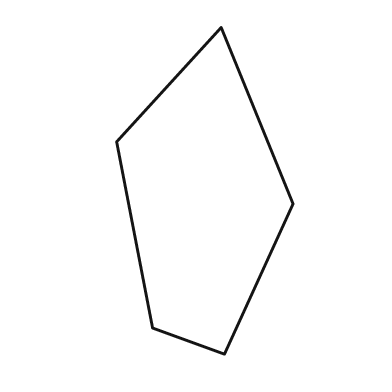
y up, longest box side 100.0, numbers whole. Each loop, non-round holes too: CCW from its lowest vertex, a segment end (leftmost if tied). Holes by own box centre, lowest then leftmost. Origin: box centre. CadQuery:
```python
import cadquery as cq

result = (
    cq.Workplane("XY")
    .moveTo(6.0, -50.0)
    .lineTo(27.0, -4.0)
    .lineTo(5.0, 50.0)
    .lineTo(-27.0, 15.0)
    .lineTo(-16.0, -42.0)
    .close()
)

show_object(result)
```